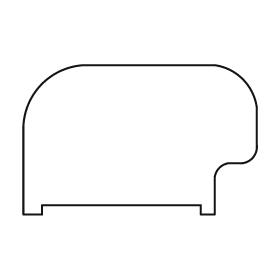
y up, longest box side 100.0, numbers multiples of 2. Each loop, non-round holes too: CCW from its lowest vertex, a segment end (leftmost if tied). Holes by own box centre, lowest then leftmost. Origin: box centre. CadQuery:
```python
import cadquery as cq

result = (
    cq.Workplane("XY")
    .moveTo(-50.0, -32.0)
    .lineTo(-42.0, -32.0)
    .lineTo(-42.0, -28.0)
    .lineTo(26.0, -28.0)
    .lineTo(26.0, -32.0)
    .lineTo(32.0, -32.0)
    .lineTo(32.0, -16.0)
    .threePointArc((34.0, -12.0), (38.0, -10.0))
    .lineTo(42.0, -10.0)
    .threePointArc((48.0, -8.0), (50.0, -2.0))
    .lineTo(50.0, 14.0)
    .threePointArc((44.0, 26.0), (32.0, 32.0))
    .lineTo(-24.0, 32.0)
    .threePointArc((-42.0, 24.0), (-50.0, 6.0))
    .close()
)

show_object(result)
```